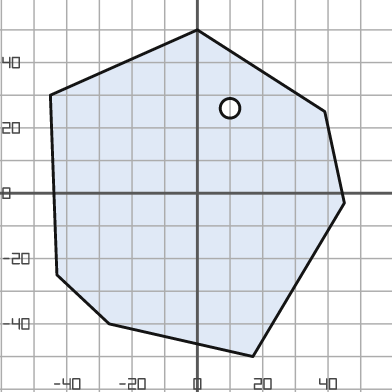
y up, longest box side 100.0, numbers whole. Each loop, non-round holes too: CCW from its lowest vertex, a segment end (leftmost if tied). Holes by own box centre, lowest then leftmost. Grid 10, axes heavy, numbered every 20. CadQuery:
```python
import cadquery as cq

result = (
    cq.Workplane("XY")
    .moveTo(17.0, -50.0)
    .lineTo(45.0, -3.0)
    .lineTo(39.0, 25.0)
    .lineTo(0.0, 50.0)
    .lineTo(-45.0, 30.0)
    .lineTo(-43.0, -25.0)
    .lineTo(-27.0, -40.0)
    .close()
    .moveTo(10.0, 26.0)
    .circle(3.0)
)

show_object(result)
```